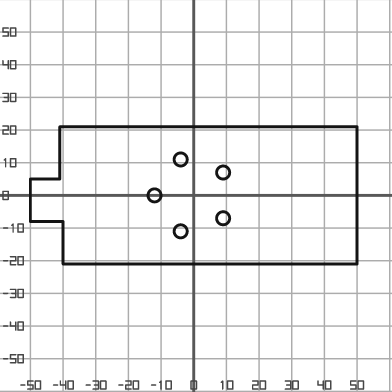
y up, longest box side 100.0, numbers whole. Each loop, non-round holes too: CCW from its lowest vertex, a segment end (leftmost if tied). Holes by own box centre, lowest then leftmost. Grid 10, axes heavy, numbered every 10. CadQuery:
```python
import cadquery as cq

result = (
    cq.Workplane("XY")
    .moveTo(-40.0, -21.0)
    .lineTo(50.0, -21.0)
    .lineTo(50.0, 21.0)
    .lineTo(-41.0, 21.0)
    .lineTo(-41.0, 5.0)
    .lineTo(-50.0, 5.0)
    .lineTo(-50.0, -8.0)
    .lineTo(-40.0, -8.0)
    .close()
    .moveTo(-4.0, -11.0)
    .circle(2.0)
    .moveTo(9.0, -7.0)
    .circle(2.0)
    .moveTo(-12.0, 0.0)
    .circle(2.0)
    .moveTo(9.0, 7.0)
    .circle(2.0)
    .moveTo(-4.0, 11.0)
    .circle(2.0)
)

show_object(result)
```